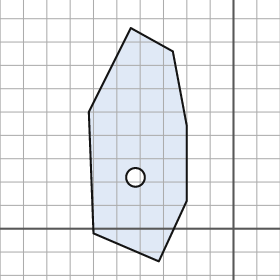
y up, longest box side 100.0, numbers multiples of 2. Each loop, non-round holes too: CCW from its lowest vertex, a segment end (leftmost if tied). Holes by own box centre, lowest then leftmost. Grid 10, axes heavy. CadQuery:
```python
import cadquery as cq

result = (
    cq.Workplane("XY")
    .moveTo(-32.0, -14.0)
    .lineTo(-20.0, 12.0)
    .lineTo(-20.0, 44.0)
    .lineTo(-26.0, 76.0)
    .lineTo(-44.0, 86.0)
    .lineTo(-62.0, 50.0)
    .lineTo(-60.0, -2.0)
    .close()
    .moveTo(-42.0, 22.0)
    .circle(4.0)
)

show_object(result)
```